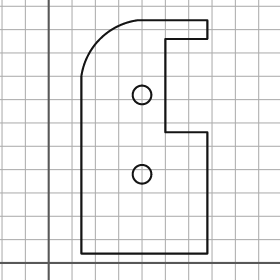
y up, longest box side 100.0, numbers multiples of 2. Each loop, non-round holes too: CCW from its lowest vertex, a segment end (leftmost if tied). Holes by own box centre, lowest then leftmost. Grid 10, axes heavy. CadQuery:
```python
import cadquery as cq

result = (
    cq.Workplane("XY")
    .moveTo(14.0, 4.0)
    .lineTo(68.0, 4.0)
    .lineTo(68.0, 56.0)
    .lineTo(50.0, 56.0)
    .lineTo(50.0, 96.0)
    .lineTo(68.0, 96.0)
    .lineTo(68.0, 104.0)
    .lineTo(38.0, 104.0)
    .threePointArc((22.0, 96.0), (14.0, 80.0))
    .close()
    .moveTo(40.0, 38.0)
    .circle(4.0)
    .moveTo(40.0, 72.0)
    .circle(4.0)
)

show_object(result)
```